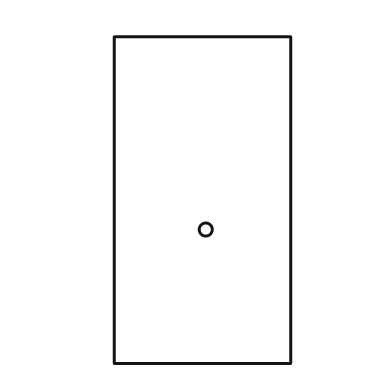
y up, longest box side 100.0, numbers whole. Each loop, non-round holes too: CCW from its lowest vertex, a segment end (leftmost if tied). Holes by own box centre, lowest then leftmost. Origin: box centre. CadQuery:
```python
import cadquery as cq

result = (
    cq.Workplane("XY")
    .moveTo(-27.0, -50.0)
    .lineTo(27.0, -50.0)
    .lineTo(27.0, 50.0)
    .lineTo(-27.0, 50.0)
    .close()
    .moveTo(1.0, -9.0)
    .circle(2.0)
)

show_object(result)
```